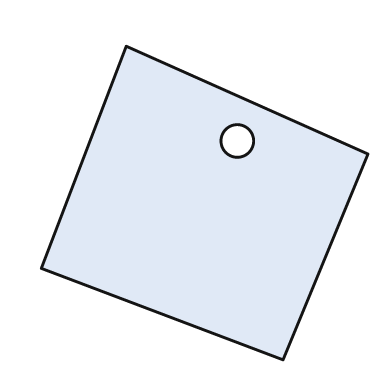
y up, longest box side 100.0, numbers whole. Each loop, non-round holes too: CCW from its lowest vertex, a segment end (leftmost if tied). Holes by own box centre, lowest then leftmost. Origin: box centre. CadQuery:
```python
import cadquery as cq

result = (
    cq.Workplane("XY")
    .moveTo(24.0, -48.0)
    .lineTo(50.0, 15.0)
    .lineTo(-24.0, 48.0)
    .lineTo(-50.0, -20.0)
    .close()
    .moveTo(10.0, 19.0)
    .circle(5.0)
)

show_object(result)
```